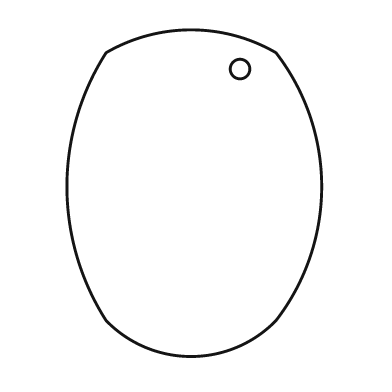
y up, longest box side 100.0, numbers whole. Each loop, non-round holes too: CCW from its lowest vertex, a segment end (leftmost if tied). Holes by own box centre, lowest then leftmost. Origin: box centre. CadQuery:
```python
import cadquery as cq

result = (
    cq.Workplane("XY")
    .moveTo(-27.0, -39.0)
    .threePointArc((-1.0, -50.0), (25.0, -39.0))
    .threePointArc((39.0, 2.0), (25.0, 43.0))
    .threePointArc((-1.0, 50.0), (-27.0, 43.0))
    .threePointArc((-39.0, 2.0), (-27.0, -39.0))
    .close()
    .moveTo(14.0, 38.0)
    .circle(3.0)
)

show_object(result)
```